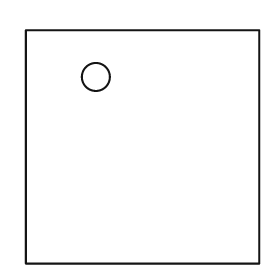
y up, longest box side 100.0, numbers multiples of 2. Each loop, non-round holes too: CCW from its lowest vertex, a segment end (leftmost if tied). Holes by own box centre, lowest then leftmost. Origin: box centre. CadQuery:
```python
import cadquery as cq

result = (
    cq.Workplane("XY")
    .moveTo(-50.0, -50.0)
    .lineTo(50.0, -50.0)
    .lineTo(50.0, 50.0)
    .lineTo(-50.0, 50.0)
    .close()
    .moveTo(-20.0, 30.0)
    .circle(6.0)
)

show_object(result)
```